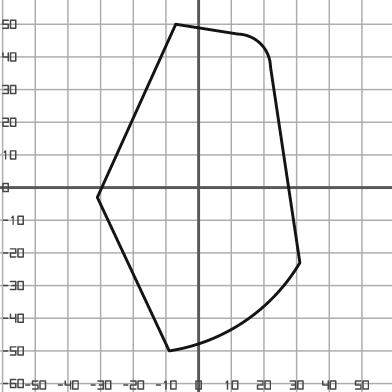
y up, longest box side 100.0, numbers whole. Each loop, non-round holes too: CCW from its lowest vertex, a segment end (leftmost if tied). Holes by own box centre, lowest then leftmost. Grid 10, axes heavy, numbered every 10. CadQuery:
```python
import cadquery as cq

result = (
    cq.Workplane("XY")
    .moveTo(-9.0, -50.0)
    .threePointArc((14.0, -41.0), (31.0, -23.0))
    .lineTo(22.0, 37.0)
    .threePointArc((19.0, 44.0), (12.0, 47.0))
    .lineTo(-7.0, 50.0)
    .lineTo(-31.0, -3.0)
    .close()
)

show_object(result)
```